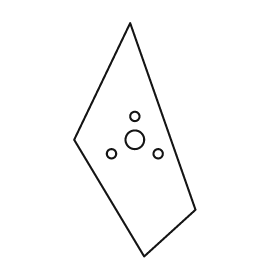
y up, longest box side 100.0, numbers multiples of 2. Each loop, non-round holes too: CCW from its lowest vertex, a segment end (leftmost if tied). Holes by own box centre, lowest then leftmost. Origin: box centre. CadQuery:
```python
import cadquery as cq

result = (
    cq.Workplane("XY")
    .moveTo(4.0, -50.0)
    .lineTo(26.0, -30.0)
    .lineTo(-2.0, 50.0)
    .lineTo(-26.0, 0.0)
    .close()
    .moveTo(-10.0, -6.0)
    .circle(2.0)
    .moveTo(10.0, -6.0)
    .circle(2.0)
    .moveTo(0.0, 0.0)
    .circle(4.0)
    .moveTo(0.0, 10.0)
    .circle(2.0)
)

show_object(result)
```